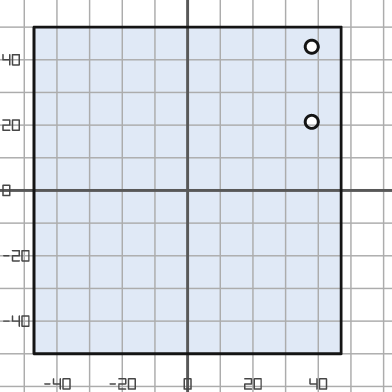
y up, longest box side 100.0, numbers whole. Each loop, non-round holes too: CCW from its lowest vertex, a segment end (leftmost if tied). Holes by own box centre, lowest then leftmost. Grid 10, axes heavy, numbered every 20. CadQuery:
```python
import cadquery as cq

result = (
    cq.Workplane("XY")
    .moveTo(-47.0, -50.0)
    .lineTo(47.0, -50.0)
    .lineTo(47.0, 50.0)
    .lineTo(-47.0, 50.0)
    .close()
    .moveTo(38.0, 21.0)
    .circle(2.0)
    .moveTo(38.0, 44.0)
    .circle(2.0)
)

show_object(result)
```